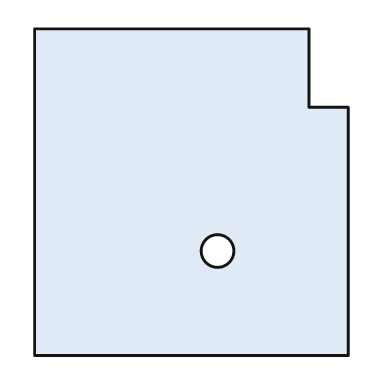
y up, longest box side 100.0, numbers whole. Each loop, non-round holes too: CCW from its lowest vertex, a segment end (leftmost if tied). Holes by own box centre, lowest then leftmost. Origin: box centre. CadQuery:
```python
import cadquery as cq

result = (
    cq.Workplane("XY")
    .moveTo(-48.0, -50.0)
    .lineTo(48.0, -50.0)
    .lineTo(48.0, 26.0)
    .lineTo(36.0, 26.0)
    .lineTo(36.0, 50.0)
    .lineTo(-48.0, 50.0)
    .close()
    .moveTo(8.0, -18.0)
    .circle(5.0)
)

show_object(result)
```